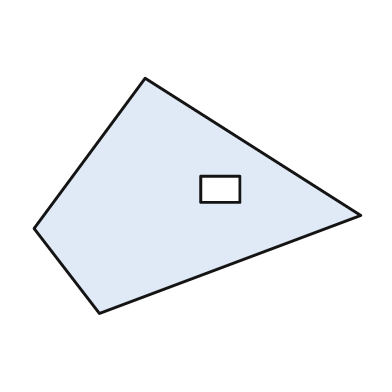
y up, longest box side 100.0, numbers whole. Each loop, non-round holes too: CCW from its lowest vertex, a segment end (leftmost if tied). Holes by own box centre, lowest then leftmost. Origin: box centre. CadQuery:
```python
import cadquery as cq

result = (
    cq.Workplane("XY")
    .moveTo(-30.0, -36.0)
    .lineTo(50.0, -6.0)
    .lineTo(-16.0, 36.0)
    .lineTo(-50.0, -10.0)
    .close()
    .moveTo(1.0, -2.0)
    .lineTo(13.0, -2.0)
    .lineTo(13.0, 6.0)
    .lineTo(1.0, 6.0)
    .close()
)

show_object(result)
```